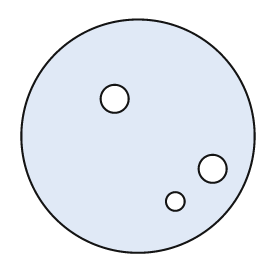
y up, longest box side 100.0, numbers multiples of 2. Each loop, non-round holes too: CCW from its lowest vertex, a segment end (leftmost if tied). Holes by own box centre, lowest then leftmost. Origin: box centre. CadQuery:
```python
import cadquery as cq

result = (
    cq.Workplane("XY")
    .moveTo(0.0, 0.0)
    .circle(50.0)
    .moveTo(16.0, -28.0)
    .circle(4.0)
    .moveTo(32.0, -14.0)
    .circle(6.0)
    .moveTo(-10.0, 16.0)
    .circle(6.0)
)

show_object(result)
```